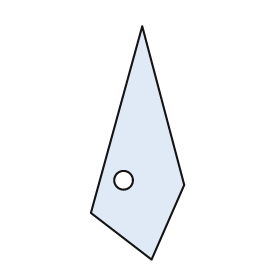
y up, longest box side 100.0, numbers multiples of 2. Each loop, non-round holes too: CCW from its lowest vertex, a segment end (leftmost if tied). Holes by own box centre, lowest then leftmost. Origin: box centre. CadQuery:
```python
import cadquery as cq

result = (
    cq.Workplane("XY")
    .moveTo(6.0, -50.0)
    .lineTo(20.0, -18.0)
    .lineTo(2.0, 50.0)
    .lineTo(-20.0, -30.0)
    .close()
    .moveTo(-6.0, -16.0)
    .circle(4.0)
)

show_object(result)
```